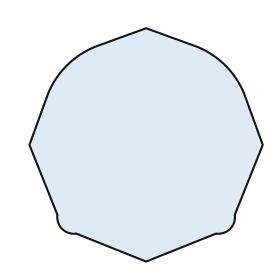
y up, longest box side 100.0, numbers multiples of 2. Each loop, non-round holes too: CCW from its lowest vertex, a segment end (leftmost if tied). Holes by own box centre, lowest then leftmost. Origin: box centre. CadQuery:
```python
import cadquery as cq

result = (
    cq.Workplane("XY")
    .moveTo(0.0, -50.0)
    .lineTo(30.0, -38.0)
    .threePointArc((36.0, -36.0), (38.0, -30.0))
    .lineTo(50.0, 0.0)
    .lineTo(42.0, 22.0)
    .threePointArc((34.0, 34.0), (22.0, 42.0))
    .lineTo(0.0, 50.0)
    .lineTo(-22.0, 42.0)
    .threePointArc((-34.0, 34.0), (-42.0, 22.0))
    .lineTo(-50.0, 0.0)
    .lineTo(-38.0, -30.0)
    .threePointArc((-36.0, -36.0), (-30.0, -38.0))
    .close()
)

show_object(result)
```